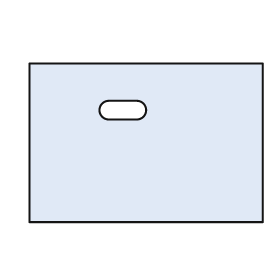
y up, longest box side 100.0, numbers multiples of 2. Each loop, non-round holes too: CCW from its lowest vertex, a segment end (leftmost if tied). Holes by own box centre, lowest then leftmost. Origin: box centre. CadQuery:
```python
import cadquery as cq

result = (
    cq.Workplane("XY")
    .moveTo(-50.0, -34.0)
    .lineTo(50.0, -34.0)
    .lineTo(50.0, 34.0)
    .lineTo(-50.0, 34.0)
    .close()
    .moveTo(-16.0, 10.0)
    .lineTo(-4.0, 10.0)
    .threePointArc((0.0, 14.0), (-4.0, 18.0))
    .lineTo(-16.0, 18.0)
    .threePointArc((-20.0, 14.0), (-16.0, 10.0))
    .close()
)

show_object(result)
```